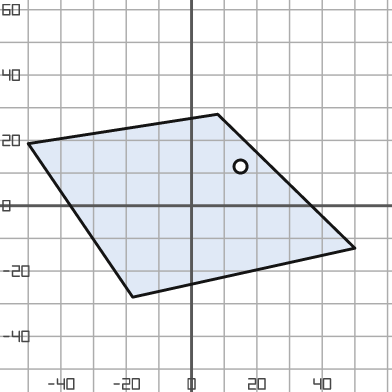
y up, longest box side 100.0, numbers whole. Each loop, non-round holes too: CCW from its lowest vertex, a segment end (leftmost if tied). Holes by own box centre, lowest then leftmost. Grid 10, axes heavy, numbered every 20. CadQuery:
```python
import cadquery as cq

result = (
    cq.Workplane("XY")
    .moveTo(-18.0, -28.0)
    .lineTo(50.0, -13.0)
    .lineTo(8.0, 28.0)
    .lineTo(-50.0, 19.0)
    .close()
    .moveTo(15.0, 12.0)
    .circle(2.0)
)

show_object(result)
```